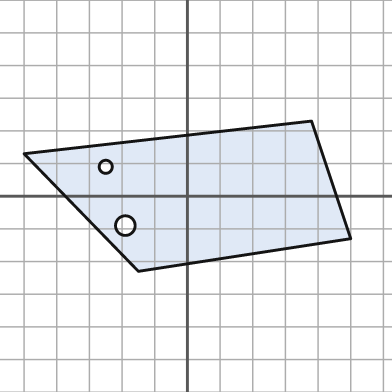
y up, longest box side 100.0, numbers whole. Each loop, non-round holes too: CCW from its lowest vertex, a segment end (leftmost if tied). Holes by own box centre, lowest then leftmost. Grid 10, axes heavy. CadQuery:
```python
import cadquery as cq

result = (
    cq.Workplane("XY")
    .moveTo(-15.0, -23.0)
    .lineTo(50.0, -13.0)
    .lineTo(38.0, 23.0)
    .lineTo(-50.0, 13.0)
    .close()
    .moveTo(-19.0, -9.0)
    .circle(3.0)
    .moveTo(-25.0, 9.0)
    .circle(2.0)
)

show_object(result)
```